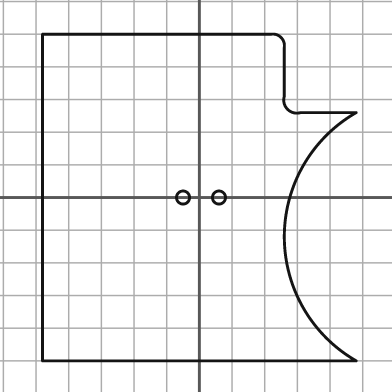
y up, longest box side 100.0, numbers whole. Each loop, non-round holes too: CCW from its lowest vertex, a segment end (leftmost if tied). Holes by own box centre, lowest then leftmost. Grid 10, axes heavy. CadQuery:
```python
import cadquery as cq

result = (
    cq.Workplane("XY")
    .moveTo(-48.0, -50.0)
    .lineTo(48.0, -50.0)
    .threePointArc((26.0, -12.0), (48.0, 26.0))
    .lineTo(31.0, 26.0)
    .threePointArc((27.0, 27.0), (26.0, 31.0))
    .lineTo(26.0, 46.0)
    .threePointArc((25.0, 49.0), (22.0, 50.0))
    .lineTo(-48.0, 50.0)
    .close()
    .moveTo(-5.0, 0.0)
    .circle(2.0)
    .moveTo(6.0, 0.0)
    .circle(2.0)
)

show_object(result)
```